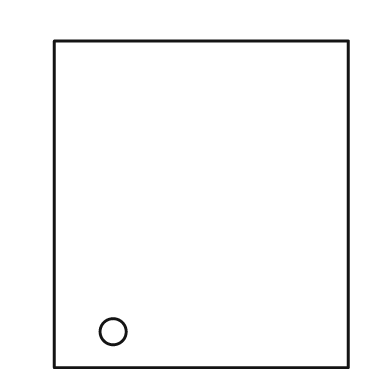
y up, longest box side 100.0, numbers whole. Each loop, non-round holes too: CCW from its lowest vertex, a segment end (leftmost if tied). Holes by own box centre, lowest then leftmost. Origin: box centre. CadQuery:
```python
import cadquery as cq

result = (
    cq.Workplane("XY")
    .moveTo(-45.0, -50.0)
    .lineTo(45.0, -50.0)
    .lineTo(45.0, 50.0)
    .lineTo(-45.0, 50.0)
    .close()
    .moveTo(-27.0, -39.0)
    .circle(4.0)
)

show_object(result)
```